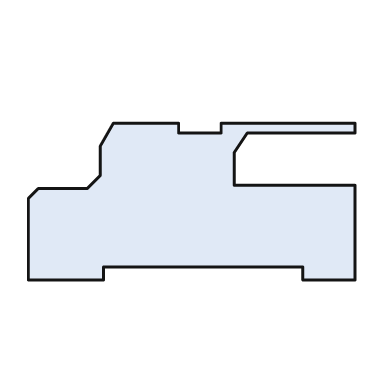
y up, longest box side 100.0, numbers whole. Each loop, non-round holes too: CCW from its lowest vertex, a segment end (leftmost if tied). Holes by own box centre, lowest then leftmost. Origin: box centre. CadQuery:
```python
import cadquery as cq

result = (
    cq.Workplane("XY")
    .moveTo(-50.0, -24.0)
    .lineTo(-27.0, -24.0)
    .lineTo(-27.0, -20.0)
    .lineTo(34.0, -20.0)
    .lineTo(34.0, -24.0)
    .lineTo(50.0, -24.0)
    .lineTo(50.0, 5.0)
    .lineTo(13.0, 5.0)
    .lineTo(13.0, 15.0)
    .lineTo(17.0, 21.0)
    .lineTo(50.0, 21.0)
    .lineTo(50.0, 24.0)
    .lineTo(9.0, 24.0)
    .lineTo(9.0, 21.0)
    .lineTo(-4.0, 21.0)
    .lineTo(-4.0, 24.0)
    .lineTo(-24.0, 24.0)
    .lineTo(-28.0, 17.0)
    .lineTo(-28.0, 8.0)
    .lineTo(-32.0, 4.0)
    .lineTo(-47.0, 4.0)
    .lineTo(-50.0, 1.0)
    .close()
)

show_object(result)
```